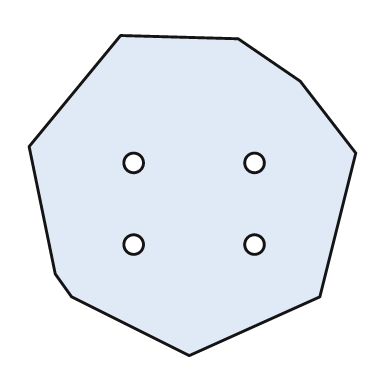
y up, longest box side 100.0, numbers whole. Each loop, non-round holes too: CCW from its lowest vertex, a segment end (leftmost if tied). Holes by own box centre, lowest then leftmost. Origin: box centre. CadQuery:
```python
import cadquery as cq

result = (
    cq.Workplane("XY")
    .moveTo(-1.0, -49.0)
    .lineTo(39.0, -31.0)
    .lineTo(50.0, 13.0)
    .lineTo(33.0, 35.0)
    .lineTo(14.0, 48.0)
    .lineTo(-22.0, 49.0)
    .lineTo(-50.0, 15.0)
    .lineTo(-42.0, -24.0)
    .lineTo(-37.0, -31.0)
    .close()
    .moveTo(-18.0, -15.0)
    .circle(3.0)
    .moveTo(19.0, -15.0)
    .circle(3.0)
    .moveTo(-18.0, 10.0)
    .circle(3.0)
    .moveTo(19.0, 10.0)
    .circle(3.0)
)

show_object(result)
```